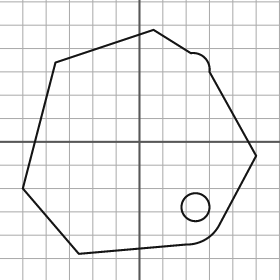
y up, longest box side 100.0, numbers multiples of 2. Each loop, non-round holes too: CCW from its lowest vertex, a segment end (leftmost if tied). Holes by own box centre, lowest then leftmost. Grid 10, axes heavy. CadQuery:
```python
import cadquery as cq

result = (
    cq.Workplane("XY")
    .moveTo(-26.0, -48.0)
    .lineTo(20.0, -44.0)
    .threePointArc((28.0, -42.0), (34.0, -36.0))
    .lineTo(50.0, -6.0)
    .lineTo(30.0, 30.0)
    .threePointArc((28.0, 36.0), (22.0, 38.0))
    .lineTo(6.0, 48.0)
    .lineTo(-36.0, 34.0)
    .lineTo(-50.0, -20.0)
    .close()
    .moveTo(24.0, -28.0)
    .circle(6.0)
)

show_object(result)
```